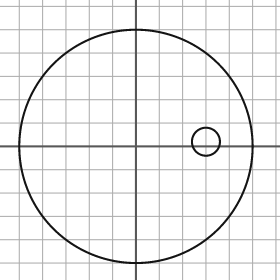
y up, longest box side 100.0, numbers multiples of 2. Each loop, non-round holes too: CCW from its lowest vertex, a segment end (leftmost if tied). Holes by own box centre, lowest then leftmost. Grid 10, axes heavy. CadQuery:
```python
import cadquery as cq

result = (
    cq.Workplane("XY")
    .moveTo(0.0, 0.0)
    .circle(50.0)
    .moveTo(30.0, 2.0)
    .circle(6.0)
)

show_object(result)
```